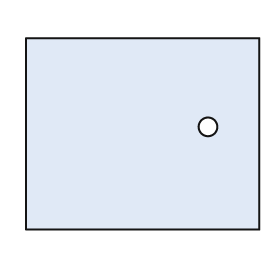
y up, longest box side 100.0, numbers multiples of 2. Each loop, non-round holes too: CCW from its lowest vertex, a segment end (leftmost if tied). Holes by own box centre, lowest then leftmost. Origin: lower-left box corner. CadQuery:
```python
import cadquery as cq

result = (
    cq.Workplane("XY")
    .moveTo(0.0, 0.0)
    .lineTo(100.0, 0.0)
    .lineTo(100.0, 82.0)
    .lineTo(0.0, 82.0)
    .close()
    .moveTo(78.0, 44.0)
    .circle(4.0)
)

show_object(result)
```